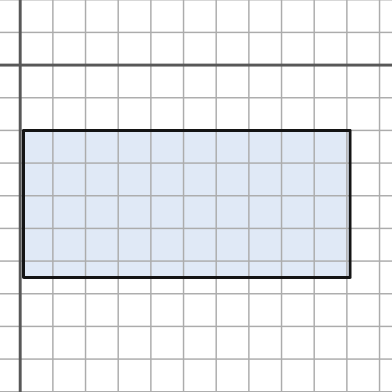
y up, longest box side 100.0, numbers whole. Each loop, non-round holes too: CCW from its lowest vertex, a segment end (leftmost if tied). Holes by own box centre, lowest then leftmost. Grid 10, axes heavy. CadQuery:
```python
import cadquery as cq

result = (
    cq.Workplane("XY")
    .moveTo(1.0, -65.0)
    .lineTo(101.0, -65.0)
    .lineTo(101.0, -20.0)
    .lineTo(1.0, -20.0)
    .close()
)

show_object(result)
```